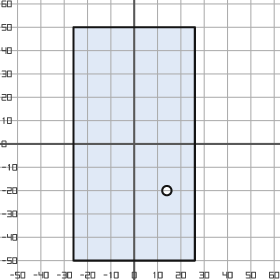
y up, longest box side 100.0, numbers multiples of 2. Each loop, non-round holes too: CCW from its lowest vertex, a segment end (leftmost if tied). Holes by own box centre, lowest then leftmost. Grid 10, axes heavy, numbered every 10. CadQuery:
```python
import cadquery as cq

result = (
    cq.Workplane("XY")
    .moveTo(-26.0, -50.0)
    .lineTo(26.0, -50.0)
    .lineTo(26.0, 50.0)
    .lineTo(-26.0, 50.0)
    .close()
    .moveTo(14.0, -20.0)
    .circle(2.0)
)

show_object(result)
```